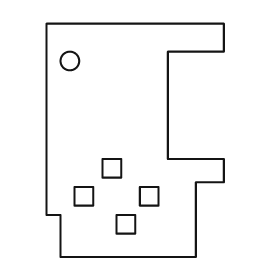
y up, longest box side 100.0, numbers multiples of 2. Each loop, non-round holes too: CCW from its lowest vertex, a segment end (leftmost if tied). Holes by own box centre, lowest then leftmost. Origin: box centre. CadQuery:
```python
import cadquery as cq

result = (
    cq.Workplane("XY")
    .moveTo(-32.0, -50.0)
    .lineTo(26.0, -50.0)
    .lineTo(26.0, -18.0)
    .lineTo(38.0, -18.0)
    .lineTo(38.0, -8.0)
    .lineTo(14.0, -8.0)
    .lineTo(14.0, 38.0)
    .lineTo(38.0, 38.0)
    .lineTo(38.0, 50.0)
    .lineTo(-38.0, 50.0)
    .lineTo(-38.0, -32.0)
    .lineTo(-32.0, -32.0)
    .close()
    .moveTo(-8.0, -40.0)
    .lineTo(0.0, -40.0)
    .lineTo(0.0, -32.0)
    .lineTo(-8.0, -32.0)
    .close()
    .moveTo(-26.0, -28.0)
    .lineTo(-18.0, -28.0)
    .lineTo(-18.0, -20.0)
    .lineTo(-26.0, -20.0)
    .close()
    .moveTo(2.0, -28.0)
    .lineTo(10.0, -28.0)
    .lineTo(10.0, -20.0)
    .lineTo(2.0, -20.0)
    .close()
    .moveTo(-14.0, -16.0)
    .lineTo(-6.0, -16.0)
    .lineTo(-6.0, -8.0)
    .lineTo(-14.0, -8.0)
    .close()
    .moveTo(-28.0, 34.0)
    .circle(4.0)
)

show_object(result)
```